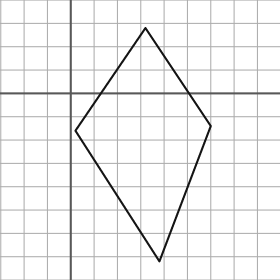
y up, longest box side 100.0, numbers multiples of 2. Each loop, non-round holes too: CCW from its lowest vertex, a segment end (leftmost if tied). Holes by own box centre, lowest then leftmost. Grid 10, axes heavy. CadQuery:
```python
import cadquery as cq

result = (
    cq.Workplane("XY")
    .moveTo(38.0, -72.0)
    .lineTo(60.0, -14.0)
    .lineTo(32.0, 28.0)
    .lineTo(2.0, -16.0)
    .close()
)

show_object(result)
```